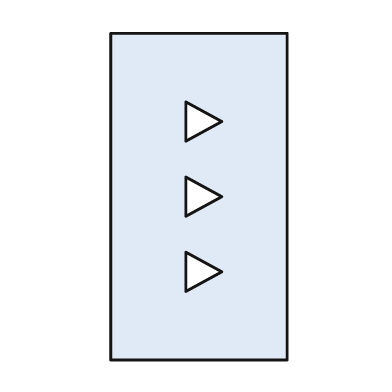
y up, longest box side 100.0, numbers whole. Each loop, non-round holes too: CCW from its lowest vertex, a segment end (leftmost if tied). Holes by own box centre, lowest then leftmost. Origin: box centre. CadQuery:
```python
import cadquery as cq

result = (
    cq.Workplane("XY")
    .moveTo(-27.0, -50.0)
    .lineTo(27.0, -50.0)
    .lineTo(27.0, 50.0)
    .lineTo(-27.0, 50.0)
    .close()
    .moveTo(-4.0, -29.0)
    .lineTo(7.0, -23.0)
    .lineTo(-4.0, -17.0)
    .close()
    .moveTo(-4.0, -6.0)
    .lineTo(7.0, 0.0)
    .lineTo(-4.0, 6.0)
    .close()
    .moveTo(-4.0, 17.0)
    .lineTo(7.0, 23.0)
    .lineTo(-4.0, 29.0)
    .close()
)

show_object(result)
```